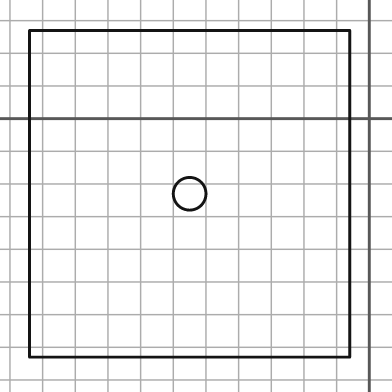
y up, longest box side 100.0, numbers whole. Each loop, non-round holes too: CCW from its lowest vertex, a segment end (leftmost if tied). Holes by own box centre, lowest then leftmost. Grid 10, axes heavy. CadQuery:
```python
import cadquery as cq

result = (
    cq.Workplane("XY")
    .moveTo(-104.0, -73.0)
    .lineTo(-6.0, -73.0)
    .lineTo(-6.0, 27.0)
    .lineTo(-104.0, 27.0)
    .close()
    .moveTo(-55.0, -23.0)
    .circle(5.0)
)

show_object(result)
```